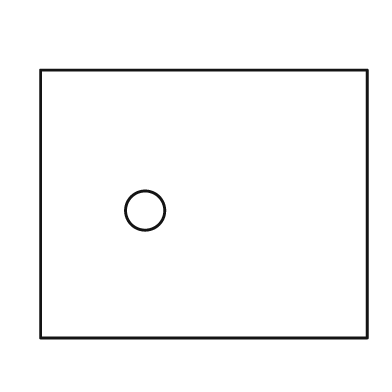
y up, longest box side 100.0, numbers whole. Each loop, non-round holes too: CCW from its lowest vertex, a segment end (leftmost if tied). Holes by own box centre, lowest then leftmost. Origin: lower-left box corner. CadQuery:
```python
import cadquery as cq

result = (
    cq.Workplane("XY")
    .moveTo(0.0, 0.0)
    .lineTo(100.0, 0.0)
    .lineTo(100.0, 82.0)
    .lineTo(0.0, 82.0)
    .close()
    .moveTo(32.0, 39.0)
    .circle(6.0)
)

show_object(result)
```